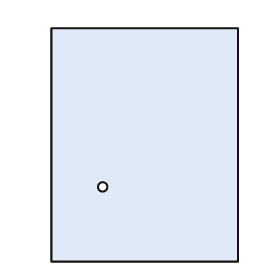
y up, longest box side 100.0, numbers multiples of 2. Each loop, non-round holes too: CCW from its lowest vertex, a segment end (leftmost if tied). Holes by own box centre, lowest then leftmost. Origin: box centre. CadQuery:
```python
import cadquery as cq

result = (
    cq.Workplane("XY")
    .moveTo(-40.0, -50.0)
    .lineTo(40.0, -50.0)
    .lineTo(40.0, 50.0)
    .lineTo(-40.0, 50.0)
    .close()
    .moveTo(-18.0, -18.0)
    .circle(2.0)
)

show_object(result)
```